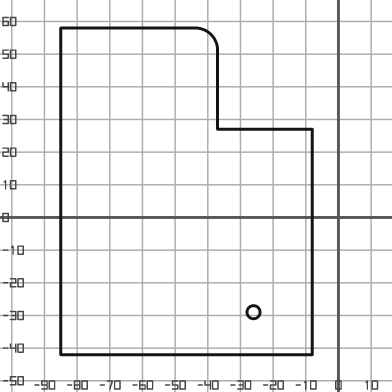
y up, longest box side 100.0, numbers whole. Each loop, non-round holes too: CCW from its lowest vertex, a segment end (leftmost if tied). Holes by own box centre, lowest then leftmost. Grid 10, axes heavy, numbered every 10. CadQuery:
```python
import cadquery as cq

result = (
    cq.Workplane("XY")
    .moveTo(-85.0, -42.0)
    .lineTo(-8.0, -42.0)
    .lineTo(-8.0, 27.0)
    .lineTo(-37.0, 27.0)
    .lineTo(-37.0, 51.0)
    .threePointArc((-39.0, 56.0), (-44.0, 58.0))
    .lineTo(-85.0, 58.0)
    .close()
    .moveTo(-26.0, -29.0)
    .circle(2.0)
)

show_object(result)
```